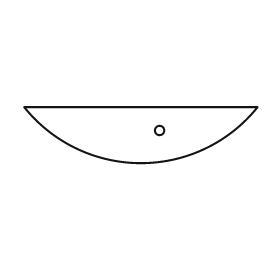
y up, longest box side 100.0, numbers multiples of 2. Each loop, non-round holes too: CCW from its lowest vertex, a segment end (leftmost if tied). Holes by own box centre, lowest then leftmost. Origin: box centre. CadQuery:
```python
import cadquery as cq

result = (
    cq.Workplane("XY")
    .moveTo(-50.0, 12.0)
    .threePointArc((0.0, -12.0), (50.0, 12.0))
    .close()
    .moveTo(8.0, 2.0)
    .circle(2.0)
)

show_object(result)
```